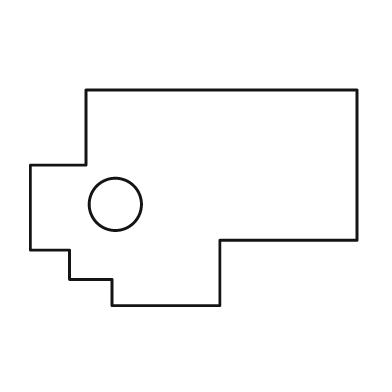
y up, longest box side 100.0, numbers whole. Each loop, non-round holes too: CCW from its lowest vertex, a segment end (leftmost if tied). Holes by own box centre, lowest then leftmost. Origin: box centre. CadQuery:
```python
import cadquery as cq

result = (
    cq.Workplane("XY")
    .moveTo(-25.0, -33.0)
    .lineTo(8.0, -33.0)
    .lineTo(8.0, -13.0)
    .lineTo(50.0, -13.0)
    .lineTo(50.0, 33.0)
    .lineTo(-33.0, 33.0)
    .lineTo(-33.0, 10.0)
    .lineTo(-50.0, 10.0)
    .lineTo(-50.0, -16.0)
    .lineTo(-38.0, -16.0)
    .lineTo(-38.0, -25.0)
    .lineTo(-25.0, -25.0)
    .close()
    .moveTo(-24.0, -2.0)
    .circle(8.0)
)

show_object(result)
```